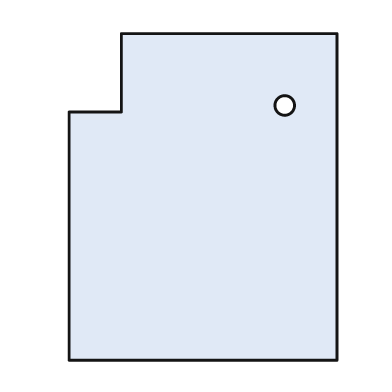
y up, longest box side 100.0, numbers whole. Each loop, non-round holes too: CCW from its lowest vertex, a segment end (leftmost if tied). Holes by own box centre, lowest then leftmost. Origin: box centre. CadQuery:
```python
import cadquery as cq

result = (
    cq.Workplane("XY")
    .moveTo(-41.0, -50.0)
    .lineTo(41.0, -50.0)
    .lineTo(41.0, 50.0)
    .lineTo(-25.0, 50.0)
    .lineTo(-25.0, 26.0)
    .lineTo(-41.0, 26.0)
    .close()
    .moveTo(25.0, 28.0)
    .circle(3.0)
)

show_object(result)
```